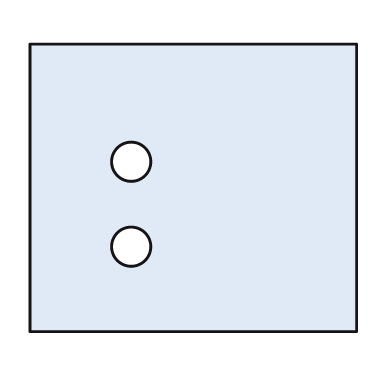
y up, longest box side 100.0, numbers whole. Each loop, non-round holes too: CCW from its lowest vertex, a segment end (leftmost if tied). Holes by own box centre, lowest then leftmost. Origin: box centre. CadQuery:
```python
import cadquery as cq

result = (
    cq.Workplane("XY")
    .moveTo(-50.0, -44.0)
    .lineTo(50.0, -44.0)
    .lineTo(50.0, 44.0)
    .lineTo(-50.0, 44.0)
    .close()
    .moveTo(-19.0, -18.0)
    .circle(6.0)
    .moveTo(-19.0, 8.0)
    .circle(6.0)
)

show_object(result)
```